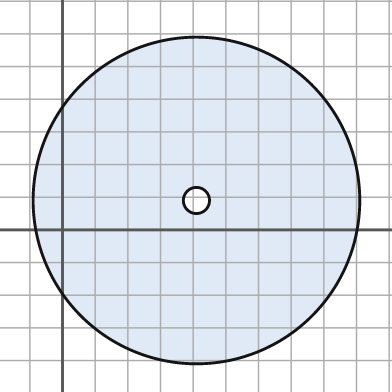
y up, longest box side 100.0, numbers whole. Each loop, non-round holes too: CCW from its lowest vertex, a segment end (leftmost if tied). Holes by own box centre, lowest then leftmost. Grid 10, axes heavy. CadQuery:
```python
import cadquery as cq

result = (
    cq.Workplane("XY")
    .moveTo(41.0, 9.0)
    .circle(50.0)
    .moveTo(41.0, 9.0)
    .circle(4.0)
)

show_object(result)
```